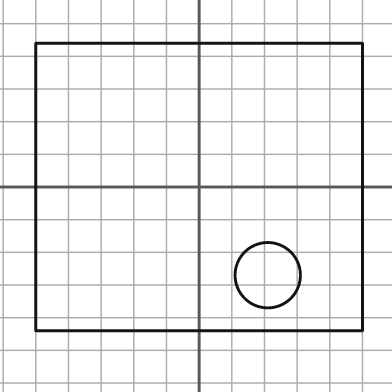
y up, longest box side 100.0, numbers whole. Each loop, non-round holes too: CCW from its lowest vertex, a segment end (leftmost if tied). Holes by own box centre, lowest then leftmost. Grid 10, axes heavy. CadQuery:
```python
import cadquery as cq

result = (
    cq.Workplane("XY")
    .moveTo(-50.0, -44.0)
    .lineTo(50.0, -44.0)
    .lineTo(50.0, 44.0)
    .lineTo(-50.0, 44.0)
    .close()
    .moveTo(21.0, -27.0)
    .circle(10.0)
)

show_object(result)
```